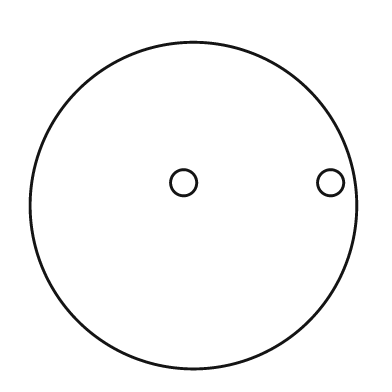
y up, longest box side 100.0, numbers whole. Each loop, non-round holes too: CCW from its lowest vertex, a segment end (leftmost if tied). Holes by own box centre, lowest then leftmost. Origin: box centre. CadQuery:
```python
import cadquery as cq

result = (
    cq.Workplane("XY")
    .moveTo(0.0, 0.0)
    .circle(50.0)
    .moveTo(-3.0, 7.0)
    .circle(4.0)
    .moveTo(42.0, 7.0)
    .circle(4.0)
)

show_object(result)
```